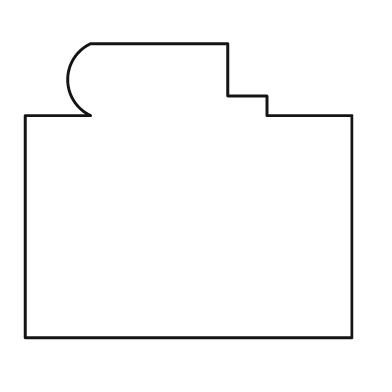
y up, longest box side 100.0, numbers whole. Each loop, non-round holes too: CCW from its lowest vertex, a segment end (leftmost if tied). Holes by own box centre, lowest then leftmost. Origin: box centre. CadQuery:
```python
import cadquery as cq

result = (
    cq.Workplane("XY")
    .moveTo(-50.0, -45.0)
    .lineTo(50.0, -45.0)
    .lineTo(50.0, 23.0)
    .lineTo(24.0, 23.0)
    .lineTo(24.0, 29.0)
    .lineTo(12.0, 29.0)
    .lineTo(12.0, 45.0)
    .lineTo(-30.0, 45.0)
    .threePointArc((-37.0, 34.0), (-30.0, 23.0))
    .lineTo(-50.0, 23.0)
    .close()
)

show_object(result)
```